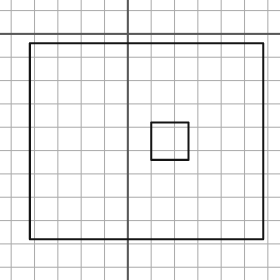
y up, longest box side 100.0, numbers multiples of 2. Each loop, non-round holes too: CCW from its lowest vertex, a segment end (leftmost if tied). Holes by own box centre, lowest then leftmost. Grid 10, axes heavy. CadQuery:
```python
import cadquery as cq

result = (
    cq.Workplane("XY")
    .moveTo(-42.0, -88.0)
    .lineTo(58.0, -88.0)
    .lineTo(58.0, -4.0)
    .lineTo(-42.0, -4.0)
    .close()
    .moveTo(10.0, -54.0)
    .lineTo(26.0, -54.0)
    .lineTo(26.0, -38.0)
    .lineTo(10.0, -38.0)
    .close()
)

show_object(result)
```